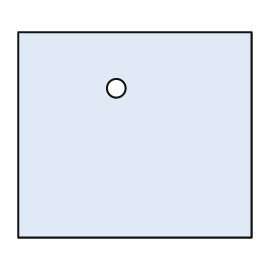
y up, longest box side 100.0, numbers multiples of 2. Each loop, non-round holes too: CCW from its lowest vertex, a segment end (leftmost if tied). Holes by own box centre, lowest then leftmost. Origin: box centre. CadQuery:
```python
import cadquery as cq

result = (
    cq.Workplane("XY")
    .moveTo(-50.0, -44.0)
    .lineTo(50.0, -44.0)
    .lineTo(50.0, 44.0)
    .lineTo(-50.0, 44.0)
    .close()
    .moveTo(-8.0, 20.0)
    .circle(4.0)
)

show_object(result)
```